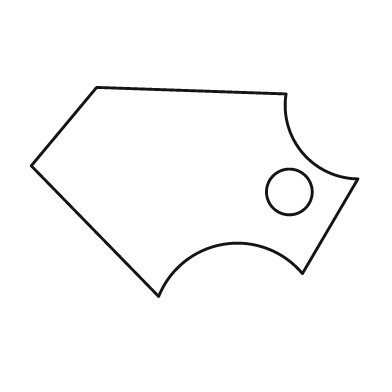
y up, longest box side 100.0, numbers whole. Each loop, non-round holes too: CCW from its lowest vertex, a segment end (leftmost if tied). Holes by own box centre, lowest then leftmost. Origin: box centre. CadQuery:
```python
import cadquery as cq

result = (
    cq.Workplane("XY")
    .moveTo(-11.0, -32.0)
    .threePointArc((9.0, -16.0), (33.0, -25.0))
    .lineTo(50.0, 4.0)
    .threePointArc((33.0, 12.0), (28.0, 30.0))
    .lineTo(-30.0, 32.0)
    .lineTo(-50.0, 8.0)
    .close()
    .moveTo(29.0, 0.0)
    .circle(7.0)
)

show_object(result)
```